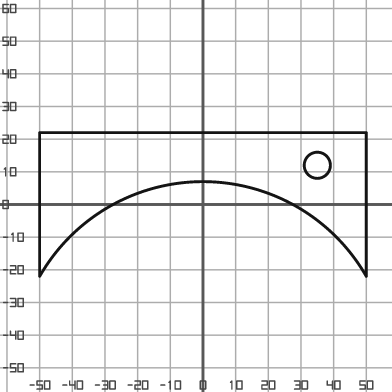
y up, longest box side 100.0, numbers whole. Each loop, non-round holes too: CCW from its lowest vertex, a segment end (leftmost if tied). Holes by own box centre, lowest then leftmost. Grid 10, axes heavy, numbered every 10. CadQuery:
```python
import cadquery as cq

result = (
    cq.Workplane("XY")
    .moveTo(-50.0, -22.0)
    .threePointArc((0.0, 7.0), (50.0, -22.0))
    .lineTo(50.0, 22.0)
    .lineTo(-50.0, 22.0)
    .close()
    .moveTo(35.0, 12.0)
    .circle(4.0)
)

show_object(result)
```